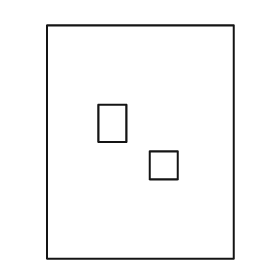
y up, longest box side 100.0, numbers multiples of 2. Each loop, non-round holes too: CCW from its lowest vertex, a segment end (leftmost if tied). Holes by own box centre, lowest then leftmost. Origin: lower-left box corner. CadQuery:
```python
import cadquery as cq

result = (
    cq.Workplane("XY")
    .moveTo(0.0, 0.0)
    .lineTo(80.0, 0.0)
    .lineTo(80.0, 100.0)
    .lineTo(0.0, 100.0)
    .close()
    .moveTo(44.0, 34.0)
    .lineTo(56.0, 34.0)
    .lineTo(56.0, 46.0)
    .lineTo(44.0, 46.0)
    .close()
    .moveTo(22.0, 50.0)
    .lineTo(34.0, 50.0)
    .lineTo(34.0, 66.0)
    .lineTo(22.0, 66.0)
    .close()
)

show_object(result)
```